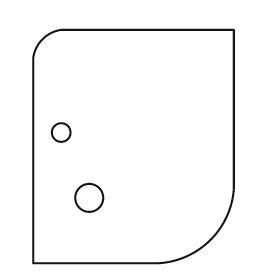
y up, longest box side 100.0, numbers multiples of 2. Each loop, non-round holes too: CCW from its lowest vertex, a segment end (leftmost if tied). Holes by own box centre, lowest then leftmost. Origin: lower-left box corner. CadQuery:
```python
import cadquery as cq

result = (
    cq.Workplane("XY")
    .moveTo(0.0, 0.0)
    .lineTo(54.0, 0.0)
    .threePointArc((76.0, 10.0), (86.0, 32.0))
    .lineTo(86.0, 100.0)
    .lineTo(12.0, 100.0)
    .threePointArc((4.0, 96.0), (0.0, 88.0))
    .close()
    .moveTo(24.0, 28.0)
    .circle(6.0)
    .moveTo(12.0, 56.0)
    .circle(4.0)
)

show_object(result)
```